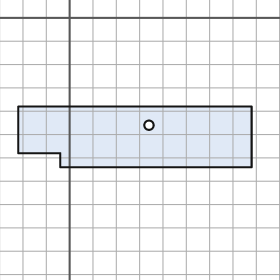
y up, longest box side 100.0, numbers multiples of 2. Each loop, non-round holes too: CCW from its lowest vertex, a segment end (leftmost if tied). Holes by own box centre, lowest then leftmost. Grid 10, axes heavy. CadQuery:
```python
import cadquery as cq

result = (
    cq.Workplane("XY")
    .moveTo(-4.0, -64.0)
    .lineTo(78.0, -64.0)
    .lineTo(78.0, -38.0)
    .lineTo(-22.0, -38.0)
    .lineTo(-22.0, -58.0)
    .lineTo(-4.0, -58.0)
    .close()
    .moveTo(34.0, -46.0)
    .circle(2.0)
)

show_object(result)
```